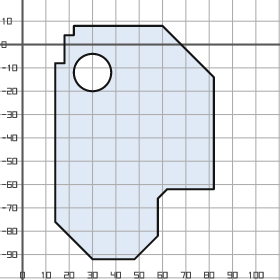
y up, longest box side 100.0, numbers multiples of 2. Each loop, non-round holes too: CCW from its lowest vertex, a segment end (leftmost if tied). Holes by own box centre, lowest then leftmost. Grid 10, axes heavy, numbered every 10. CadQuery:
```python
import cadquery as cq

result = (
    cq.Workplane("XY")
    .moveTo(30.0, -92.0)
    .lineTo(48.0, -92.0)
    .lineTo(58.0, -82.0)
    .lineTo(58.0, -66.0)
    .lineTo(62.0, -62.0)
    .lineTo(82.0, -62.0)
    .lineTo(82.0, -14.0)
    .lineTo(60.0, 8.0)
    .lineTo(22.0, 8.0)
    .lineTo(22.0, 4.0)
    .lineTo(18.0, 4.0)
    .lineTo(18.0, -8.0)
    .lineTo(14.0, -8.0)
    .lineTo(14.0, -76.0)
    .close()
    .moveTo(30.0, -12.0)
    .circle(8.0)
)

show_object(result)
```